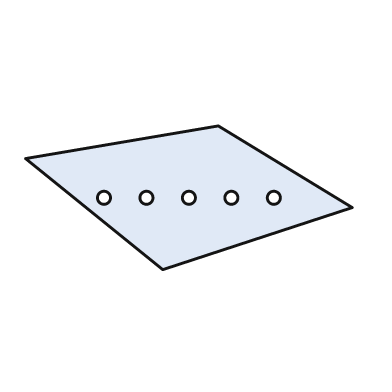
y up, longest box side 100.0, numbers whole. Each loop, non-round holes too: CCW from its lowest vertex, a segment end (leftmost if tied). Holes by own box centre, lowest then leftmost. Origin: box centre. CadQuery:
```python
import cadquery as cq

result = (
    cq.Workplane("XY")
    .moveTo(-8.0, -22.0)
    .lineTo(50.0, -3.0)
    .lineTo(9.0, 22.0)
    .lineTo(-50.0, 12.0)
    .close()
    .moveTo(-26.0, 0.0)
    .circle(2.0)
    .moveTo(-13.0, 0.0)
    .circle(2.0)
    .moveTo(0.0, 0.0)
    .circle(2.0)
    .moveTo(13.0, 0.0)
    .circle(2.0)
    .moveTo(26.0, 0.0)
    .circle(2.0)
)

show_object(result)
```